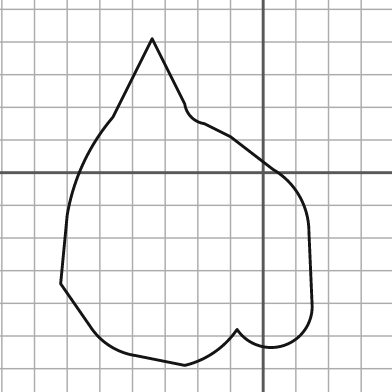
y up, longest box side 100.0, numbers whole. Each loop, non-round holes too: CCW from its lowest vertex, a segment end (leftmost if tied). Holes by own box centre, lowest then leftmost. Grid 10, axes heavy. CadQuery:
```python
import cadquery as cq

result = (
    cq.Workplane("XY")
    .moveTo(-24.0, -59.0)
    .threePointArc((-15.0, -55.0), (-8.0, -48.0))
    .threePointArc((6.0, -53.0), (15.0, -41.0))
    .lineTo(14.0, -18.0)
    .threePointArc((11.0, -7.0), (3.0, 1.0))
    .lineTo(-10.0, 11.0)
    .lineTo(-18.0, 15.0)
    .threePointArc((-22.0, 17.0), (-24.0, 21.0))
    .lineTo(-34.0, 41.0)
    .lineTo(-46.0, 17.0)
    .threePointArc((-55.0, 3.0), (-60.0, -13.0))
    .lineTo(-62.0, -34.0)
    .lineTo(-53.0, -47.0)
    .threePointArc((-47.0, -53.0), (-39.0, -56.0))
    .close()
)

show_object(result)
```